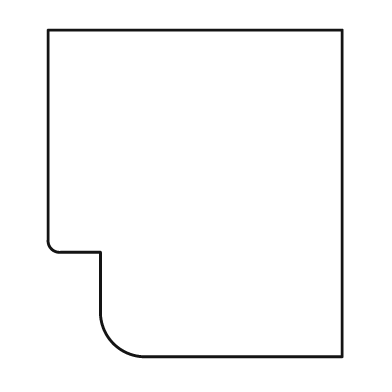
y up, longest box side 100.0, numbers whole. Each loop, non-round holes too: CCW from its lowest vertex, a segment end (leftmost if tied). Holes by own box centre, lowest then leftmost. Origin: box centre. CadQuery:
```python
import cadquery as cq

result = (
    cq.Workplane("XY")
    .moveTo(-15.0, -50.0)
    .lineTo(45.0, -50.0)
    .lineTo(45.0, 50.0)
    .lineTo(-45.0, 50.0)
    .lineTo(-45.0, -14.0)
    .threePointArc((-44.0, -17.0), (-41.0, -18.0))
    .lineTo(-29.0, -18.0)
    .lineTo(-29.0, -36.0)
    .threePointArc((-25.0, -46.0), (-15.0, -50.0))
    .close()
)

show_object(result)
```